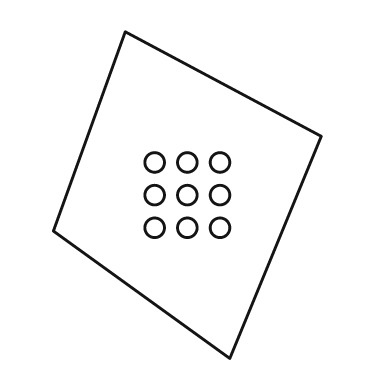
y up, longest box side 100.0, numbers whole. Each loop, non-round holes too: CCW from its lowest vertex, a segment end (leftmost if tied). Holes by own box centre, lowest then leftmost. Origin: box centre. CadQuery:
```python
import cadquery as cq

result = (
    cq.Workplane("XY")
    .moveTo(13.0, -50.0)
    .lineTo(41.0, 18.0)
    .lineTo(-19.0, 50.0)
    .lineTo(-41.0, -11.0)
    .close()
    .moveTo(-10.0, -10.0)
    .circle(3.0)
    .moveTo(0.0, -10.0)
    .circle(3.0)
    .moveTo(10.0, -10.0)
    .circle(3.0)
    .moveTo(-10.0, 0.0)
    .circle(3.0)
    .moveTo(0.0, 0.0)
    .circle(3.0)
    .moveTo(10.0, 0.0)
    .circle(3.0)
    .moveTo(-10.0, 10.0)
    .circle(3.0)
    .moveTo(0.0, 10.0)
    .circle(3.0)
    .moveTo(10.0, 10.0)
    .circle(3.0)
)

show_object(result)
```